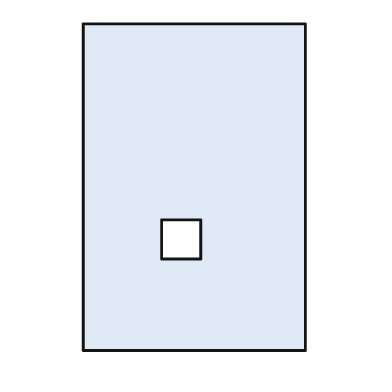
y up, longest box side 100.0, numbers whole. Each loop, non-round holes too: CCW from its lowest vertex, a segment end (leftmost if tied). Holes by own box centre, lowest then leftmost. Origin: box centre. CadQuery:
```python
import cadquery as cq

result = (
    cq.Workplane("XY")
    .moveTo(-34.0, -50.0)
    .lineTo(34.0, -50.0)
    .lineTo(34.0, 50.0)
    .lineTo(-34.0, 50.0)
    .close()
    .moveTo(-10.0, -22.0)
    .lineTo(2.0, -22.0)
    .lineTo(2.0, -10.0)
    .lineTo(-10.0, -10.0)
    .close()
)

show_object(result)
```